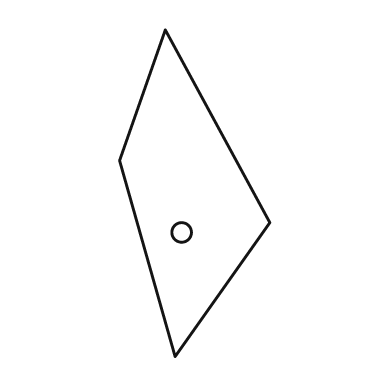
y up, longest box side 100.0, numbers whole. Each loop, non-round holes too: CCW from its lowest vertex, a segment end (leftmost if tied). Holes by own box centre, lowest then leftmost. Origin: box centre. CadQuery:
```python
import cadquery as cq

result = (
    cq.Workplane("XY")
    .moveTo(-6.0, -50.0)
    .lineTo(23.0, -9.0)
    .lineTo(-9.0, 50.0)
    .lineTo(-23.0, 10.0)
    .close()
    .moveTo(-4.0, -12.0)
    .circle(3.0)
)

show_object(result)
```